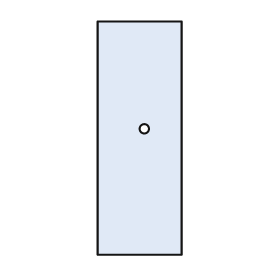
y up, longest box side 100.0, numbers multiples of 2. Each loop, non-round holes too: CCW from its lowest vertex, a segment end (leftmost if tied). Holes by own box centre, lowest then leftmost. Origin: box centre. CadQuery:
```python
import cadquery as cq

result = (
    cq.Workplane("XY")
    .moveTo(-18.0, -50.0)
    .lineTo(18.0, -50.0)
    .lineTo(18.0, 50.0)
    .lineTo(-18.0, 50.0)
    .close()
    .moveTo(2.0, 4.0)
    .circle(2.0)
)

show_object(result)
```